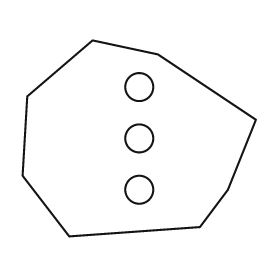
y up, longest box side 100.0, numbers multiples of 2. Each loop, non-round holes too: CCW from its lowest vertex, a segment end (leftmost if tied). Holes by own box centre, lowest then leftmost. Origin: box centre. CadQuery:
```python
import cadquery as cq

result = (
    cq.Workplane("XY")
    .moveTo(-30.0, -42.0)
    .lineTo(26.0, -38.0)
    .lineTo(38.0, -22.0)
    .lineTo(50.0, 8.0)
    .lineTo(8.0, 36.0)
    .lineTo(-20.0, 42.0)
    .lineTo(-48.0, 18.0)
    .lineTo(-50.0, -16.0)
    .close()
    .moveTo(0.0, -22.0)
    .circle(6.0)
    .moveTo(0.0, 0.0)
    .circle(6.0)
    .moveTo(0.0, 22.0)
    .circle(6.0)
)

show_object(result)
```